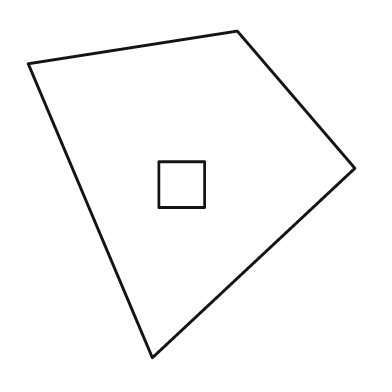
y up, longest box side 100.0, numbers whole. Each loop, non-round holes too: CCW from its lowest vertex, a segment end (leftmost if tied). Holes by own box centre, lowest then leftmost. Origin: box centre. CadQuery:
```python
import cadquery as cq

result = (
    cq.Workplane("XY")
    .moveTo(-12.0, -50.0)
    .lineTo(50.0, 8.0)
    .lineTo(14.0, 50.0)
    .lineTo(-50.0, 40.0)
    .close()
    .moveTo(-10.0, -4.0)
    .lineTo(4.0, -4.0)
    .lineTo(4.0, 10.0)
    .lineTo(-10.0, 10.0)
    .close()
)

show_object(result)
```